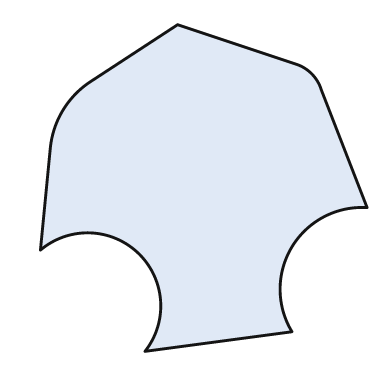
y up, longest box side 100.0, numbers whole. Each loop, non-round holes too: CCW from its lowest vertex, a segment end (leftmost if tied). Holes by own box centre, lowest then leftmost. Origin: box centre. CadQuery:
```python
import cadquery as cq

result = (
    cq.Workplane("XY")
    .moveTo(-18.0, -50.0)
    .lineTo(27.0, -44.0)
    .threePointArc((27.0, -18.0), (50.0, -6.0))
    .lineTo(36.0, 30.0)
    .threePointArc((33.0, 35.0), (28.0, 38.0))
    .lineTo(-8.0, 50.0)
    .lineTo(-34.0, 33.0)
    .threePointArc((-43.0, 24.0), (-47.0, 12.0))
    .lineTo(-50.0, -19.0)
    .threePointArc((-20.0, -20.0), (-18.0, -50.0))
    .close()
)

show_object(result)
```